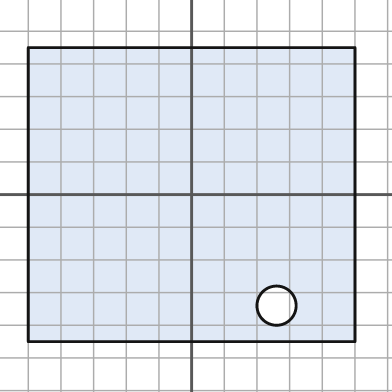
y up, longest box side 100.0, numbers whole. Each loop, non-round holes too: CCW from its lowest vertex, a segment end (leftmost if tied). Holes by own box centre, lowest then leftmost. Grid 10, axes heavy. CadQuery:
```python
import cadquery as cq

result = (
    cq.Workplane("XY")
    .moveTo(-50.0, -45.0)
    .lineTo(50.0, -45.0)
    .lineTo(50.0, 45.0)
    .lineTo(-50.0, 45.0)
    .close()
    .moveTo(26.0, -34.0)
    .circle(6.0)
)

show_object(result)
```